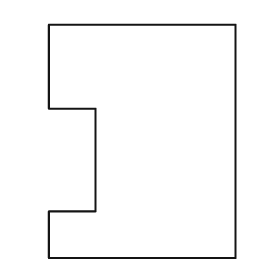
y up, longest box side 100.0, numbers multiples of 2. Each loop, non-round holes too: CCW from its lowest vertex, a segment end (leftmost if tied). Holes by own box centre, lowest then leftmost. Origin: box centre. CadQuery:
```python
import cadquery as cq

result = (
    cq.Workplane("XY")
    .moveTo(-40.0, -50.0)
    .lineTo(40.0, -50.0)
    .lineTo(40.0, 50.0)
    .lineTo(-40.0, 50.0)
    .lineTo(-40.0, 14.0)
    .lineTo(-20.0, 14.0)
    .lineTo(-20.0, -30.0)
    .lineTo(-40.0, -30.0)
    .close()
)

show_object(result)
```